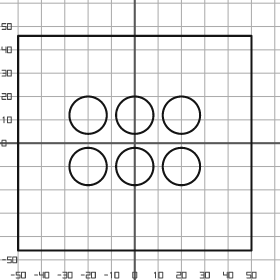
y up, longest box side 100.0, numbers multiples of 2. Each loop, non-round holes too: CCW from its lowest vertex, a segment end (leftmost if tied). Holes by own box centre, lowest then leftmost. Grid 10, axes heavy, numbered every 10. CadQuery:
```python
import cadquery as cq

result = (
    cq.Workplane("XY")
    .moveTo(-50.0, -46.0)
    .lineTo(50.0, -46.0)
    .lineTo(50.0, 46.0)
    .lineTo(-50.0, 46.0)
    .close()
    .moveTo(-20.0, -10.0)
    .circle(8.0)
    .moveTo(0.0, -10.0)
    .circle(8.0)
    .moveTo(20.0, -10.0)
    .circle(8.0)
    .moveTo(-20.0, 12.0)
    .circle(8.0)
    .moveTo(0.0, 12.0)
    .circle(8.0)
    .moveTo(20.0, 12.0)
    .circle(8.0)
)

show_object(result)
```